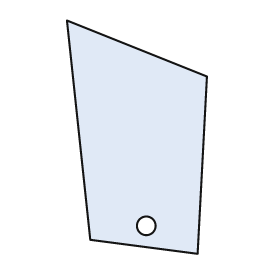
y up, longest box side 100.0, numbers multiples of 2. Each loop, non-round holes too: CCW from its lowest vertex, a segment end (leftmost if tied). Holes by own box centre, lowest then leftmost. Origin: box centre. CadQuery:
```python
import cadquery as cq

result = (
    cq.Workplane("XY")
    .moveTo(26.0, -50.0)
    .lineTo(30.0, 26.0)
    .lineTo(-30.0, 50.0)
    .lineTo(-20.0, -44.0)
    .close()
    .moveTo(4.0, -38.0)
    .circle(4.0)
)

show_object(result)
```